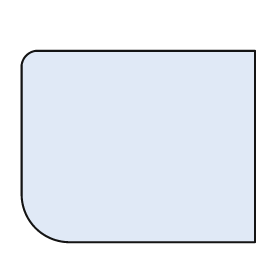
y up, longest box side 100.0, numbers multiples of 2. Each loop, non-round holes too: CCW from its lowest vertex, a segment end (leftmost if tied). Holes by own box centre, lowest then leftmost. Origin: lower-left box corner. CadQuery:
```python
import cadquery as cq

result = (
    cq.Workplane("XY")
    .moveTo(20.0, 0.0)
    .lineTo(100.0, 0.0)
    .lineTo(100.0, 82.0)
    .lineTo(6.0, 82.0)
    .threePointArc((2.0, 80.0), (0.0, 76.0))
    .lineTo(0.0, 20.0)
    .threePointArc((6.0, 6.0), (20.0, 0.0))
    .close()
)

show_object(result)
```